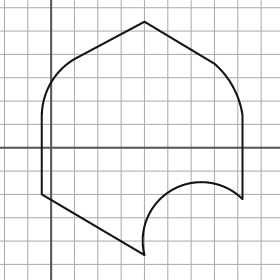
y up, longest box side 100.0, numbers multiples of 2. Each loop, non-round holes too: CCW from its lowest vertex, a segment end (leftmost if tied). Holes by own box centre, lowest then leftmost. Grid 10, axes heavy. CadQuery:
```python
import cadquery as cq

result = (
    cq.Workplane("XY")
    .moveTo(40.0, -46.0)
    .threePointArc((52.0, -18.0), (82.0, -22.0))
    .lineTo(82.0, 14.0)
    .threePointArc((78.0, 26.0), (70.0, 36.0))
    .lineTo(40.0, 54.0)
    .lineTo(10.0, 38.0)
    .threePointArc((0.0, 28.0), (-4.0, 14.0))
    .lineTo(-4.0, -20.0)
    .close()
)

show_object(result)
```